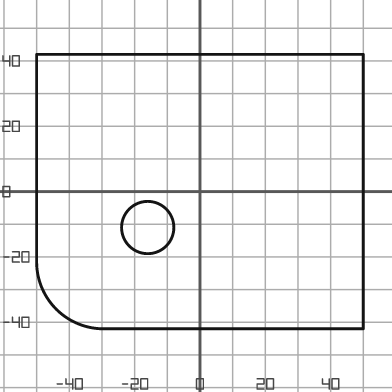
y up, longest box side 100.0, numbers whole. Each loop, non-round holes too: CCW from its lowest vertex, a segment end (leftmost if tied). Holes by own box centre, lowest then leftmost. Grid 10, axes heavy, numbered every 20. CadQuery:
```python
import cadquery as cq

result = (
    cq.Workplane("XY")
    .moveTo(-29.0, -42.0)
    .lineTo(50.0, -42.0)
    .lineTo(50.0, 42.0)
    .lineTo(-50.0, 42.0)
    .lineTo(-50.0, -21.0)
    .threePointArc((-44.0, -36.0), (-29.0, -42.0))
    .close()
    .moveTo(-16.0, -11.0)
    .circle(8.0)
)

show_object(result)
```